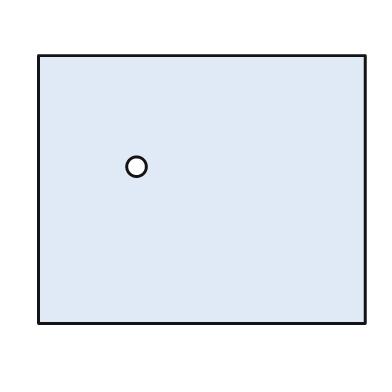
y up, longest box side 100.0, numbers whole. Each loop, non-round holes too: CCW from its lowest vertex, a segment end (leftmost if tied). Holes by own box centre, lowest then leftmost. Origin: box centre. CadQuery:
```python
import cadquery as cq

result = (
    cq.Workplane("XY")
    .moveTo(-50.0, -41.0)
    .lineTo(50.0, -41.0)
    .lineTo(50.0, 41.0)
    .lineTo(-50.0, 41.0)
    .close()
    .moveTo(-20.0, 7.0)
    .circle(3.0)
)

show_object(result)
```